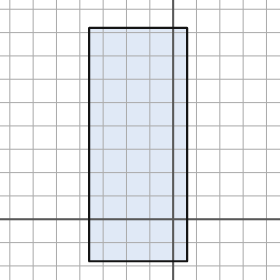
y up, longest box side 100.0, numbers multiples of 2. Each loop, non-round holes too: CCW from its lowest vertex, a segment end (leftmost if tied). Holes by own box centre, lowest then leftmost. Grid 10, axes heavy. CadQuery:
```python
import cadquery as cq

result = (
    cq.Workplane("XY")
    .moveTo(-36.0, -18.0)
    .lineTo(6.0, -18.0)
    .lineTo(6.0, 82.0)
    .lineTo(-36.0, 82.0)
    .close()
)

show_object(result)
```